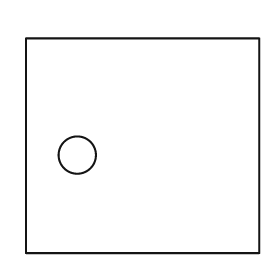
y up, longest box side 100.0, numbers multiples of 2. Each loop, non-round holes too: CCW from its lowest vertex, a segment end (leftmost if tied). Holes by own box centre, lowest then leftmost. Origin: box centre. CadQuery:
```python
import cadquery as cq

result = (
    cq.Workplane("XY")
    .moveTo(-50.0, -46.0)
    .lineTo(50.0, -46.0)
    .lineTo(50.0, 46.0)
    .lineTo(-50.0, 46.0)
    .close()
    .moveTo(-28.0, -4.0)
    .circle(8.0)
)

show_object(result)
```